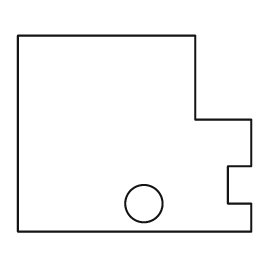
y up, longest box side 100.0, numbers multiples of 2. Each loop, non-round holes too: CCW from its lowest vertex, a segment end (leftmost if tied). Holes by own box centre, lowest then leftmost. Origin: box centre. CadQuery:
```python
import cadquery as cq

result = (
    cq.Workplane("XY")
    .moveTo(-50.0, -42.0)
    .lineTo(50.0, -42.0)
    .lineTo(50.0, -30.0)
    .lineTo(40.0, -30.0)
    .lineTo(40.0, -14.0)
    .lineTo(50.0, -14.0)
    .lineTo(50.0, 6.0)
    .lineTo(26.0, 6.0)
    .lineTo(26.0, 42.0)
    .lineTo(-50.0, 42.0)
    .close()
    .moveTo(4.0, -30.0)
    .circle(8.0)
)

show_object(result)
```